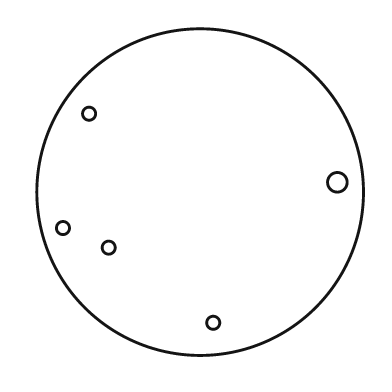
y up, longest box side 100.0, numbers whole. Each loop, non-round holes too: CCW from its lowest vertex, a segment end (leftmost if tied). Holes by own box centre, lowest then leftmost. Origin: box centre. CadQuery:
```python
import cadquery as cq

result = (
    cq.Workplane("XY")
    .moveTo(0.0, 0.0)
    .circle(50.0)
    .moveTo(4.0, -40.0)
    .circle(2.0)
    .moveTo(-28.0, -17.0)
    .circle(2.0)
    .moveTo(-42.0, -11.0)
    .circle(2.0)
    .moveTo(42.0, 3.0)
    .circle(3.0)
    .moveTo(-34.0, 24.0)
    .circle(2.0)
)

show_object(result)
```